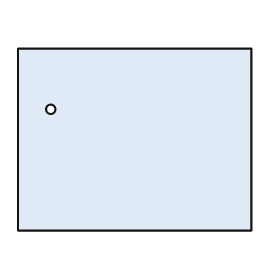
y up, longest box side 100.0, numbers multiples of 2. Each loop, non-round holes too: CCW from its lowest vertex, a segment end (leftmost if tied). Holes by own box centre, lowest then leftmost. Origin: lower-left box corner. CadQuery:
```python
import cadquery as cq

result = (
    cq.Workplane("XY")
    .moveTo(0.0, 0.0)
    .lineTo(100.0, 0.0)
    .lineTo(100.0, 78.0)
    .lineTo(0.0, 78.0)
    .close()
    .moveTo(14.0, 52.0)
    .circle(2.0)
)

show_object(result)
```